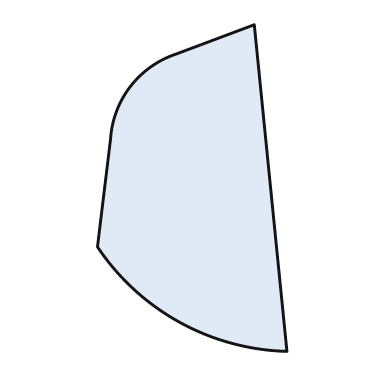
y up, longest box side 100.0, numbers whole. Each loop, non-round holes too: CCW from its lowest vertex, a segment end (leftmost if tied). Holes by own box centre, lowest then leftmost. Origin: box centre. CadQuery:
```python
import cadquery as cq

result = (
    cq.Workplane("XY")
    .moveTo(29.0, -50.0)
    .lineTo(19.0, 50.0)
    .lineTo(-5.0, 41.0)
    .threePointArc((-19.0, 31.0), (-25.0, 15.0))
    .lineTo(-29.0, -18.0)
    .threePointArc((-4.0, -41.0), (29.0, -50.0))
    .close()
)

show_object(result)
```